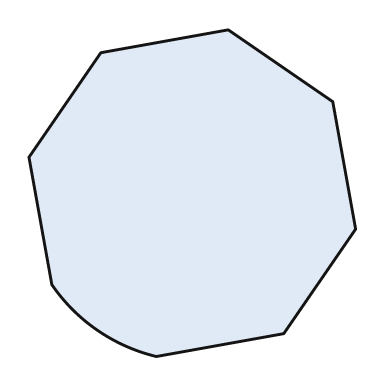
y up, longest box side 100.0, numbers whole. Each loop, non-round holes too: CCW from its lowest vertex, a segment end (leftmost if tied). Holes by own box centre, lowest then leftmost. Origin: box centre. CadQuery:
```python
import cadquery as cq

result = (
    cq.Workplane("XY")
    .moveTo(-11.0, -50.0)
    .lineTo(28.0, -43.0)
    .lineTo(50.0, -11.0)
    .lineTo(43.0, 28.0)
    .lineTo(11.0, 50.0)
    .lineTo(-28.0, 43.0)
    .lineTo(-50.0, 11.0)
    .lineTo(-43.0, -28.0)
    .threePointArc((-29.0, -42.0), (-11.0, -50.0))
    .close()
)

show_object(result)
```